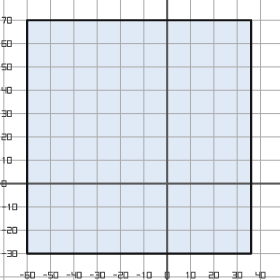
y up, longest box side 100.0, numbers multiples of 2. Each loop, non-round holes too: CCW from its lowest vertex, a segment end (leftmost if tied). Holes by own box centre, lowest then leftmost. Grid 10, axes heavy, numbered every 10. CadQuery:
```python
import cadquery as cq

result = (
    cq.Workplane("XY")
    .moveTo(-60.0, -30.0)
    .lineTo(36.0, -30.0)
    .lineTo(36.0, 70.0)
    .lineTo(-60.0, 70.0)
    .close()
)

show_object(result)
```